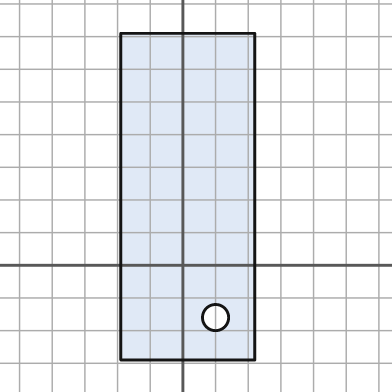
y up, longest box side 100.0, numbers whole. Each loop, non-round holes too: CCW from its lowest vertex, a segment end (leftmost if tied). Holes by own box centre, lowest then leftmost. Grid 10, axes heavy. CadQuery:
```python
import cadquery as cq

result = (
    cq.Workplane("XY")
    .moveTo(-19.0, -29.0)
    .lineTo(22.0, -29.0)
    .lineTo(22.0, 71.0)
    .lineTo(-19.0, 71.0)
    .close()
    .moveTo(10.0, -16.0)
    .circle(4.0)
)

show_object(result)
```